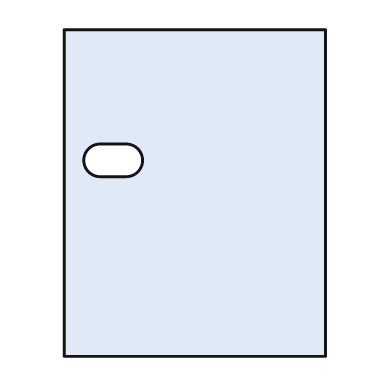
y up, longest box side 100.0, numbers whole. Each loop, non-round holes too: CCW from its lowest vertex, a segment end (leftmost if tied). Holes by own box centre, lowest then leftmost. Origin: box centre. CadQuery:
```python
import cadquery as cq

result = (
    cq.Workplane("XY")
    .moveTo(-40.0, -50.0)
    .lineTo(40.0, -50.0)
    .lineTo(40.0, 50.0)
    .lineTo(-40.0, 50.0)
    .close()
    .moveTo(-29.0, 5.0)
    .lineTo(-21.0, 5.0)
    .threePointArc((-16.0, 10.0), (-21.0, 15.0))
    .lineTo(-29.0, 15.0)
    .threePointArc((-34.0, 10.0), (-29.0, 5.0))
    .close()
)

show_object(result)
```